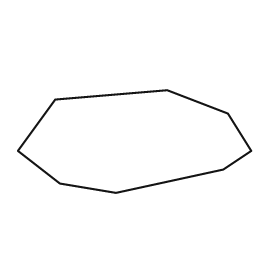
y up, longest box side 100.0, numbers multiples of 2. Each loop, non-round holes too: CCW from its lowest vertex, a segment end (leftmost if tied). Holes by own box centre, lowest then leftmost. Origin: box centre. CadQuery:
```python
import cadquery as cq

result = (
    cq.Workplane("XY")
    .moveTo(-8.0, -22.0)
    .lineTo(38.0, -12.0)
    .lineTo(50.0, -4.0)
    .lineTo(40.0, 12.0)
    .lineTo(14.0, 22.0)
    .lineTo(-34.0, 18.0)
    .lineTo(-50.0, -4.0)
    .lineTo(-32.0, -18.0)
    .close()
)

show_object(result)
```